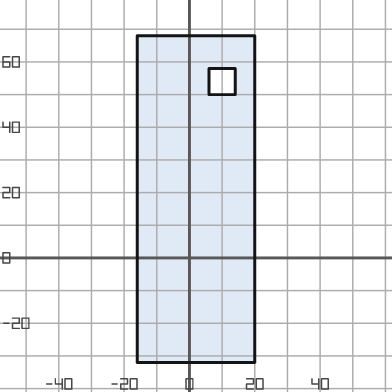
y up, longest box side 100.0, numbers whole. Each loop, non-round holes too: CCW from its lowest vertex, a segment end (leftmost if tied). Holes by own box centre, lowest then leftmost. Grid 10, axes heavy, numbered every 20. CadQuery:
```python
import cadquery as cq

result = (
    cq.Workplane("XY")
    .moveTo(-16.0, -32.0)
    .lineTo(20.0, -32.0)
    .lineTo(20.0, 68.0)
    .lineTo(-16.0, 68.0)
    .close()
    .moveTo(6.0, 50.0)
    .lineTo(14.0, 50.0)
    .lineTo(14.0, 58.0)
    .lineTo(6.0, 58.0)
    .close()
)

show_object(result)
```